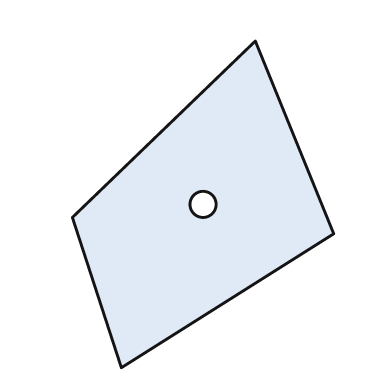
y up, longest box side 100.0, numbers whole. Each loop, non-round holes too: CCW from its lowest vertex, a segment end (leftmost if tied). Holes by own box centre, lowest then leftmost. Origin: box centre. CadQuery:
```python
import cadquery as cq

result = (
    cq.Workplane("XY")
    .moveTo(-25.0, -50.0)
    .lineTo(40.0, -9.0)
    .lineTo(16.0, 50.0)
    .lineTo(-40.0, -4.0)
    .close()
    .moveTo(0.0, 0.0)
    .circle(4.0)
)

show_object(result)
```